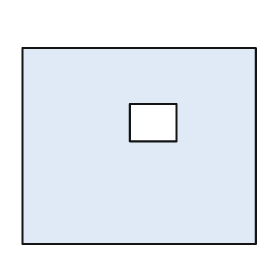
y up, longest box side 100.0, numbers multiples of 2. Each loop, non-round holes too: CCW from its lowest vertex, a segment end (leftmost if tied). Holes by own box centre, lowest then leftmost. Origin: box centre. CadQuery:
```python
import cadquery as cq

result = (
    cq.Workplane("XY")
    .moveTo(-50.0, -42.0)
    .lineTo(50.0, -42.0)
    .lineTo(50.0, 42.0)
    .lineTo(-50.0, 42.0)
    .close()
    .moveTo(-4.0, 2.0)
    .lineTo(16.0, 2.0)
    .lineTo(16.0, 18.0)
    .lineTo(-4.0, 18.0)
    .close()
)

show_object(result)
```